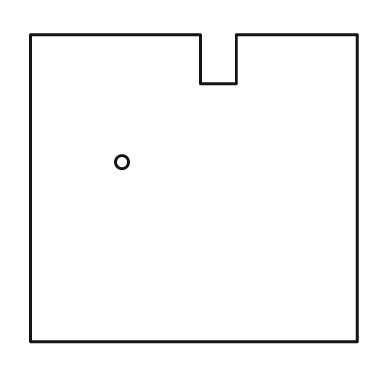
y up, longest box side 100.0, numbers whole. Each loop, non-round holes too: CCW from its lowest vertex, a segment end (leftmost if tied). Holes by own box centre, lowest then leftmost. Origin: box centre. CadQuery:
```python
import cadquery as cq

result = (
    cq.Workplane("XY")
    .moveTo(-50.0, -47.0)
    .lineTo(50.0, -47.0)
    .lineTo(50.0, 47.0)
    .lineTo(13.0, 47.0)
    .lineTo(13.0, 32.0)
    .lineTo(2.0, 32.0)
    .lineTo(2.0, 47.0)
    .lineTo(-50.0, 47.0)
    .close()
    .moveTo(-22.0, 8.0)
    .circle(2.0)
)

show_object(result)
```